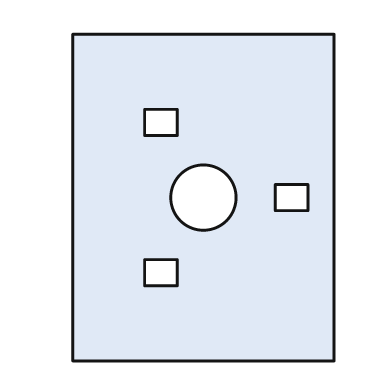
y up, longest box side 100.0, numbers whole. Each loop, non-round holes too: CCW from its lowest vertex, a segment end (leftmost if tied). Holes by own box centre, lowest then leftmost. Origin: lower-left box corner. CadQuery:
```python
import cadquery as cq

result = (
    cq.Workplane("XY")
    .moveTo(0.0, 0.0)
    .lineTo(80.0, 0.0)
    .lineTo(80.0, 100.0)
    .lineTo(0.0, 100.0)
    .close()
    .moveTo(22.0, 23.0)
    .lineTo(32.0, 23.0)
    .lineTo(32.0, 31.0)
    .lineTo(22.0, 31.0)
    .close()
    .moveTo(40.0, 50.0)
    .circle(10.0)
    .moveTo(62.0, 46.0)
    .lineTo(72.0, 46.0)
    .lineTo(72.0, 54.0)
    .lineTo(62.0, 54.0)
    .close()
    .moveTo(22.0, 69.0)
    .lineTo(32.0, 69.0)
    .lineTo(32.0, 77.0)
    .lineTo(22.0, 77.0)
    .close()
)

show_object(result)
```